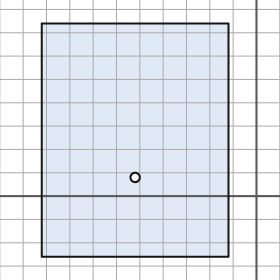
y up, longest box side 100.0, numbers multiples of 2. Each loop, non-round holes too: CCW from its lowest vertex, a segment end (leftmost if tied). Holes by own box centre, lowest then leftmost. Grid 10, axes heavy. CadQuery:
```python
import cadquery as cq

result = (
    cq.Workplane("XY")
    .moveTo(-92.0, -26.0)
    .lineTo(-12.0, -26.0)
    .lineTo(-12.0, 74.0)
    .lineTo(-92.0, 74.0)
    .close()
    .moveTo(-52.0, 8.0)
    .circle(2.0)
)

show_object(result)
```